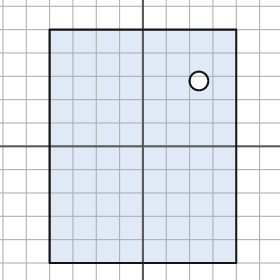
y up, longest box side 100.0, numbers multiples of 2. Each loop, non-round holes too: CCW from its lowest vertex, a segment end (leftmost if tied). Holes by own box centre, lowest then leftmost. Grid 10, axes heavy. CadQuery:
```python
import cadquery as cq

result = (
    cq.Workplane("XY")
    .moveTo(-40.0, -50.0)
    .lineTo(40.0, -50.0)
    .lineTo(40.0, 50.0)
    .lineTo(-40.0, 50.0)
    .close()
    .moveTo(24.0, 28.0)
    .circle(4.0)
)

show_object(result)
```